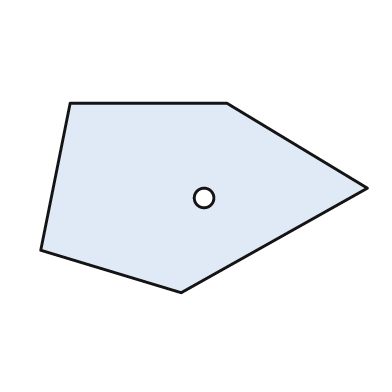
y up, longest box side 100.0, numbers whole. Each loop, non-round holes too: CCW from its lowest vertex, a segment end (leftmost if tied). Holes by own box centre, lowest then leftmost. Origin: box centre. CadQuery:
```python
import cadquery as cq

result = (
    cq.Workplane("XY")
    .moveTo(-7.0, -29.0)
    .lineTo(50.0, 3.0)
    .lineTo(7.0, 29.0)
    .lineTo(-41.0, 29.0)
    .lineTo(-50.0, -16.0)
    .close()
    .moveTo(0.0, 0.0)
    .circle(3.0)
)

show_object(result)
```